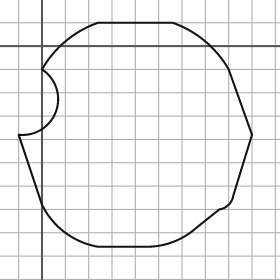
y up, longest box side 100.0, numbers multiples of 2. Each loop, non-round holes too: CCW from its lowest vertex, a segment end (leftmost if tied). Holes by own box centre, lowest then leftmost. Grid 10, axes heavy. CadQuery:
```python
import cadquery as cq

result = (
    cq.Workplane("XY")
    .moveTo(24.0, -86.0)
    .lineTo(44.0, -86.0)
    .threePointArc((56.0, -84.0), (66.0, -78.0))
    .lineTo(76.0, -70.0)
    .threePointArc((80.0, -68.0), (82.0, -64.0))
    .lineTo(90.0, -38.0)
    .lineTo(80.0, -10.0)
    .threePointArc((70.0, 2.0), (56.0, 10.0))
    .lineTo(24.0, 10.0)
    .threePointArc((10.0, 2.0), (0.0, -10.0))
    .threePointArc((6.0, -28.0), (-10.0, -38.0))
    .lineTo(0.0, -68.0)
    .threePointArc((10.0, -80.0), (24.0, -86.0))
    .close()
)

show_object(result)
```